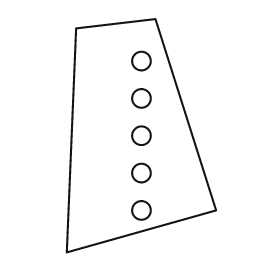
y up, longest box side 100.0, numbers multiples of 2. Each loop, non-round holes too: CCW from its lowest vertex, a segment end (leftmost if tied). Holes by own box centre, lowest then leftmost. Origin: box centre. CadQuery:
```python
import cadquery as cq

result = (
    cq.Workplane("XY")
    .moveTo(-32.0, -50.0)
    .lineTo(32.0, -32.0)
    .lineTo(6.0, 50.0)
    .lineTo(-28.0, 46.0)
    .close()
    .moveTo(0.0, -32.0)
    .circle(4.0)
    .moveTo(0.0, -16.0)
    .circle(4.0)
    .moveTo(0.0, 0.0)
    .circle(4.0)
    .moveTo(0.0, 16.0)
    .circle(4.0)
    .moveTo(0.0, 32.0)
    .circle(4.0)
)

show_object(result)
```